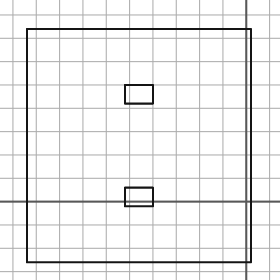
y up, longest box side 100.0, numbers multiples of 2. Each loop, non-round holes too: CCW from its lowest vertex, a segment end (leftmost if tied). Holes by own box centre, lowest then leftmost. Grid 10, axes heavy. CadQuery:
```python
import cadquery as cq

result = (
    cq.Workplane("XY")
    .moveTo(-94.0, -26.0)
    .lineTo(2.0, -26.0)
    .lineTo(2.0, 74.0)
    .lineTo(-94.0, 74.0)
    .close()
    .moveTo(-52.0, -2.0)
    .lineTo(-40.0, -2.0)
    .lineTo(-40.0, 6.0)
    .lineTo(-52.0, 6.0)
    .close()
    .moveTo(-52.0, 42.0)
    .lineTo(-40.0, 42.0)
    .lineTo(-40.0, 50.0)
    .lineTo(-52.0, 50.0)
    .close()
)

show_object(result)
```